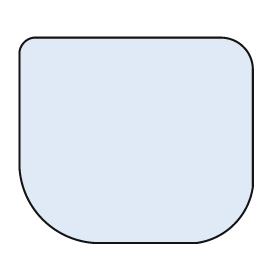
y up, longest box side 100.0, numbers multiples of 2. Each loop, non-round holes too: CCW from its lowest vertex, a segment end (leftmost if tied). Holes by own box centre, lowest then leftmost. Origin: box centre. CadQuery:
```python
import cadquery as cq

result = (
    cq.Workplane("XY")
    .moveTo(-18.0, -44.0)
    .lineTo(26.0, -44.0)
    .threePointArc((42.0, -36.0), (50.0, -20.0))
    .lineTo(50.0, 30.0)
    .threePointArc((46.0, 40.0), (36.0, 44.0))
    .lineTo(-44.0, 44.0)
    .threePointArc((-48.0, 42.0), (-50.0, 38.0))
    .lineTo(-50.0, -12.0)
    .threePointArc((-40.0, -34.0), (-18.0, -44.0))
    .close()
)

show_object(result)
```